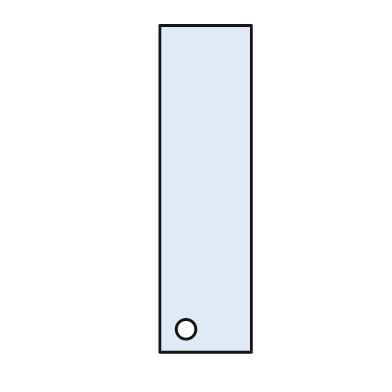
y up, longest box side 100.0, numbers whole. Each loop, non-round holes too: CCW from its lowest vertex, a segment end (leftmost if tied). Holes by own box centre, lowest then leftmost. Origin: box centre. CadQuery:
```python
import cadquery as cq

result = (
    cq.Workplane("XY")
    .moveTo(-14.0, -50.0)
    .lineTo(14.0, -50.0)
    .lineTo(14.0, 50.0)
    .lineTo(-14.0, 50.0)
    .close()
    .moveTo(-6.0, -43.0)
    .circle(3.0)
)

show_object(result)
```